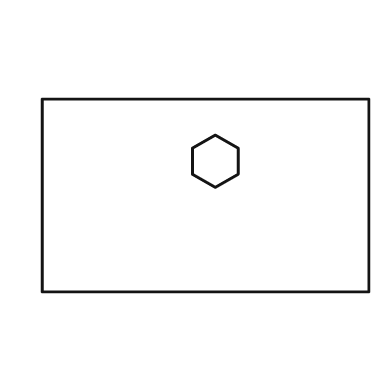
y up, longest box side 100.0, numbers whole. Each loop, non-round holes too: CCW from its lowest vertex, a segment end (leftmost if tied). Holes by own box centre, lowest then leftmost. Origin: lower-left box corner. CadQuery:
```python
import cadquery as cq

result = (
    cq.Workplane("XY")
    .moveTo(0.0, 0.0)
    .lineTo(100.0, 0.0)
    .lineTo(100.0, 59.0)
    .lineTo(0.0, 59.0)
    .close()
    .moveTo(53.0, 32.0)
    .lineTo(60.0, 36.0)
    .lineTo(60.0, 44.0)
    .lineTo(53.0, 48.0)
    .lineTo(46.0, 44.0)
    .lineTo(46.0, 36.0)
    .close()
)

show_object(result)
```